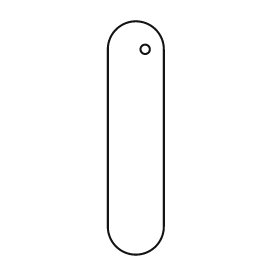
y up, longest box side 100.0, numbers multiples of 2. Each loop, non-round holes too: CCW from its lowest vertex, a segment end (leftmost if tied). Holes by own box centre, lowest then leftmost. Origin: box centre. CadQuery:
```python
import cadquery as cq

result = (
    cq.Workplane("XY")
    .moveTo(-12.0, -38.0)
    .threePointArc((0.0, -50.0), (12.0, -38.0))
    .lineTo(12.0, 38.0)
    .threePointArc((0.0, 50.0), (-12.0, 38.0))
    .close()
    .moveTo(4.0, 38.0)
    .circle(2.0)
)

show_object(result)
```